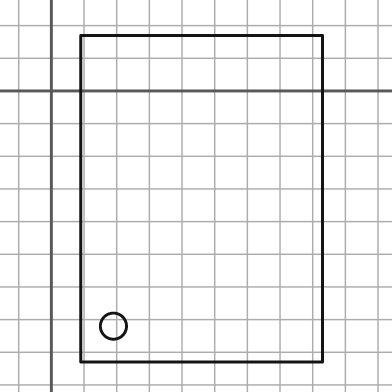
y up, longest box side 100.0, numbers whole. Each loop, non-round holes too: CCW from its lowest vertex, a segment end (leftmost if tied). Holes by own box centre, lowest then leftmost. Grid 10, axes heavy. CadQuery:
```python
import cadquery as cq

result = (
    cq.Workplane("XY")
    .moveTo(9.0, -83.0)
    .lineTo(83.0, -83.0)
    .lineTo(83.0, 17.0)
    .lineTo(9.0, 17.0)
    .close()
    .moveTo(19.0, -72.0)
    .circle(4.0)
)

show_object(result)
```